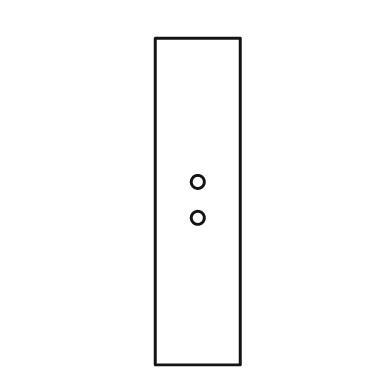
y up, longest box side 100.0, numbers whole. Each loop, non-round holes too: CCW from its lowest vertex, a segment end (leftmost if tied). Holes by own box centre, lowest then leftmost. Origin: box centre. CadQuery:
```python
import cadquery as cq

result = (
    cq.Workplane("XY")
    .moveTo(-13.0, -50.0)
    .lineTo(13.0, -50.0)
    .lineTo(13.0, 50.0)
    .lineTo(-13.0, 50.0)
    .close()
    .moveTo(0.0, -5.0)
    .circle(2.0)
    .moveTo(0.0, 6.0)
    .circle(2.0)
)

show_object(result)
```